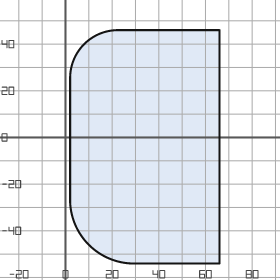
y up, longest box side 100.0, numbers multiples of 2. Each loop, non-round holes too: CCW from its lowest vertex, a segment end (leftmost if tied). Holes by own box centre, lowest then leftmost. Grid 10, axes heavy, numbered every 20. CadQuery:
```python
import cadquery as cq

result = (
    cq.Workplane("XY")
    .moveTo(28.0, -54.0)
    .lineTo(66.0, -54.0)
    .lineTo(66.0, 46.0)
    .lineTo(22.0, 46.0)
    .threePointArc((8.0, 40.0), (2.0, 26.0))
    .lineTo(2.0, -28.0)
    .threePointArc((10.0, -46.0), (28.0, -54.0))
    .close()
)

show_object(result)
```